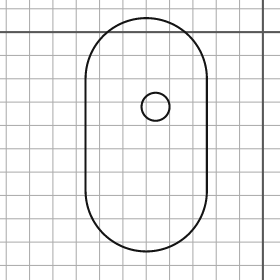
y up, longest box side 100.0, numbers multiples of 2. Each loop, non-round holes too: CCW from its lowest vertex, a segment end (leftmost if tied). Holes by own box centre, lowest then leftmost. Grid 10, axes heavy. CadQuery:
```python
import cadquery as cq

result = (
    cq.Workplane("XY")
    .moveTo(-76.0, -68.0)
    .threePointArc((-50.0, -94.0), (-24.0, -68.0))
    .lineTo(-24.0, -20.0)
    .threePointArc((-50.0, 6.0), (-76.0, -20.0))
    .close()
    .moveTo(-46.0, -32.0)
    .circle(6.0)
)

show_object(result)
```